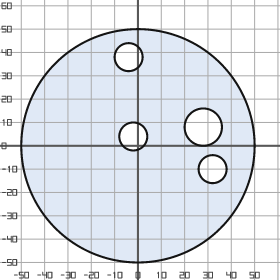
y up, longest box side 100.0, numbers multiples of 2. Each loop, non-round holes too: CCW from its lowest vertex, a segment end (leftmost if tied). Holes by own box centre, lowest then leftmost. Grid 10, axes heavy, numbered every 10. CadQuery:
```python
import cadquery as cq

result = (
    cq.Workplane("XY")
    .moveTo(0.0, 0.0)
    .circle(50.0)
    .moveTo(32.0, -10.0)
    .circle(6.0)
    .moveTo(-2.0, 4.0)
    .circle(6.0)
    .moveTo(28.0, 8.0)
    .circle(8.0)
    .moveTo(-4.0, 38.0)
    .circle(6.0)
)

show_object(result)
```